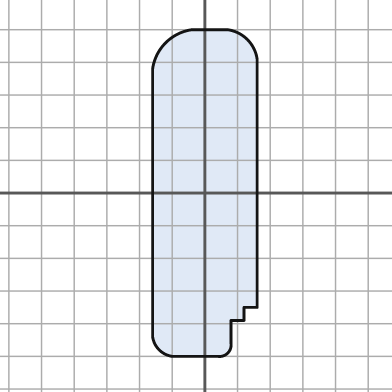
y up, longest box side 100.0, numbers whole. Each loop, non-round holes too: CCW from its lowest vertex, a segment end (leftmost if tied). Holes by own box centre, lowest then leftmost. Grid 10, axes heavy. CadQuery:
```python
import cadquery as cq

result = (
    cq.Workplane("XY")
    .moveTo(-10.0, -50.0)
    .lineTo(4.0, -50.0)
    .threePointArc((7.0, -49.0), (8.0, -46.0))
    .lineTo(8.0, -39.0)
    .lineTo(12.0, -39.0)
    .lineTo(12.0, -35.0)
    .lineTo(16.0, -35.0)
    .lineTo(16.0, 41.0)
    .threePointArc((13.0, 47.0), (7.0, 50.0))
    .lineTo(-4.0, 50.0)
    .threePointArc((-12.0, 46.0), (-16.0, 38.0))
    .lineTo(-16.0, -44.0)
    .threePointArc((-14.0, -48.0), (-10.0, -50.0))
    .close()
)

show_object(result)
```